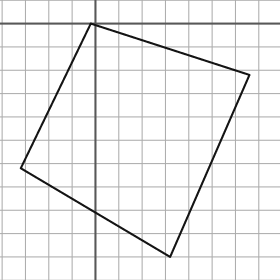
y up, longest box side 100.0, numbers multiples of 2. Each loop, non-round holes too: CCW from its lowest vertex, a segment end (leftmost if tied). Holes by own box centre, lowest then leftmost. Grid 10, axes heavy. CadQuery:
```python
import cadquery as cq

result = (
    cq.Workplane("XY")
    .moveTo(32.0, -100.0)
    .lineTo(66.0, -22.0)
    .lineTo(-2.0, 0.0)
    .lineTo(-32.0, -62.0)
    .close()
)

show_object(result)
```